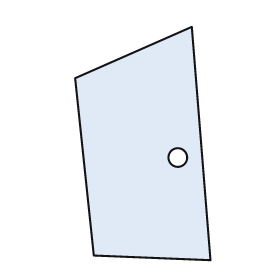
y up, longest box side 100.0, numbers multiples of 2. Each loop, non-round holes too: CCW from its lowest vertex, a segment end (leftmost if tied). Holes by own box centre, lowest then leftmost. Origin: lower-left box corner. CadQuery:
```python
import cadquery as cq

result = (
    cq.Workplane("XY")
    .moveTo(58.0, 0.0)
    .lineTo(50.0, 100.0)
    .lineTo(0.0, 78.0)
    .lineTo(8.0, 2.0)
    .close()
    .moveTo(44.0, 44.0)
    .circle(4.0)
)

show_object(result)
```